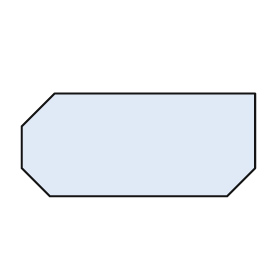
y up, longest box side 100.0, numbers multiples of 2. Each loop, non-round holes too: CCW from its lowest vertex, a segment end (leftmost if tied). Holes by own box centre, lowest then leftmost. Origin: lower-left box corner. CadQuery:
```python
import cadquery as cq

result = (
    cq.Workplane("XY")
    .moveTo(12.0, 0.0)
    .lineTo(88.0, 0.0)
    .lineTo(100.0, 12.0)
    .lineTo(100.0, 44.0)
    .lineTo(14.0, 44.0)
    .lineTo(0.0, 30.0)
    .lineTo(0.0, 12.0)
    .close()
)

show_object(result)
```